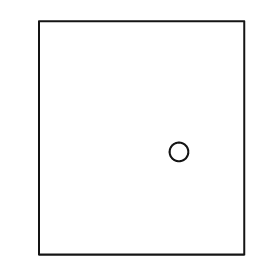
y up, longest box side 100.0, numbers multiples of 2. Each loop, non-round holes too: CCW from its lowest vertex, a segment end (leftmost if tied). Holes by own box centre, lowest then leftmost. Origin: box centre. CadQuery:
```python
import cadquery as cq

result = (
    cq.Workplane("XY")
    .moveTo(-44.0, -50.0)
    .lineTo(44.0, -50.0)
    .lineTo(44.0, 50.0)
    .lineTo(-44.0, 50.0)
    .close()
    .moveTo(16.0, -6.0)
    .circle(4.0)
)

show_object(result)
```